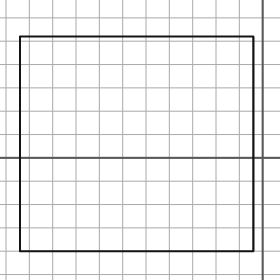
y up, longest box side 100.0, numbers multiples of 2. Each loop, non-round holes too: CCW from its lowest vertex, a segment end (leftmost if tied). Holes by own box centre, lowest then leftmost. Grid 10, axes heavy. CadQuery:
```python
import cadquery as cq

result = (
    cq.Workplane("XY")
    .moveTo(-104.0, -40.0)
    .lineTo(-4.0, -40.0)
    .lineTo(-4.0, 52.0)
    .lineTo(-104.0, 52.0)
    .close()
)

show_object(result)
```